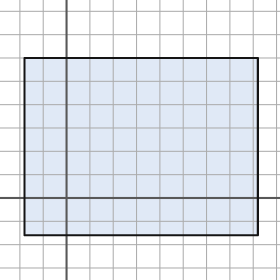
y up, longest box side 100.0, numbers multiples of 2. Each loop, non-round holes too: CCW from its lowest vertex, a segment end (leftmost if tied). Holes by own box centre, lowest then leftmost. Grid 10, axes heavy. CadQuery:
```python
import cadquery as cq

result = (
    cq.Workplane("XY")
    .moveTo(-18.0, -16.0)
    .lineTo(82.0, -16.0)
    .lineTo(82.0, 60.0)
    .lineTo(-18.0, 60.0)
    .close()
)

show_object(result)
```